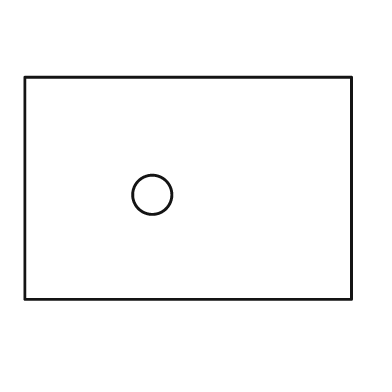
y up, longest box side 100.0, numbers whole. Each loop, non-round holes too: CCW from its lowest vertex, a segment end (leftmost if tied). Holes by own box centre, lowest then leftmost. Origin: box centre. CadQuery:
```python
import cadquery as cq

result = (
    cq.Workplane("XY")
    .moveTo(-50.0, -34.0)
    .lineTo(50.0, -34.0)
    .lineTo(50.0, 34.0)
    .lineTo(-50.0, 34.0)
    .close()
    .moveTo(-11.0, -2.0)
    .circle(6.0)
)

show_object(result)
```